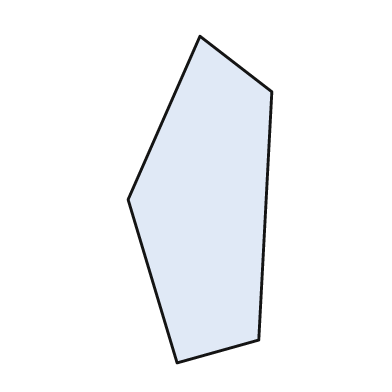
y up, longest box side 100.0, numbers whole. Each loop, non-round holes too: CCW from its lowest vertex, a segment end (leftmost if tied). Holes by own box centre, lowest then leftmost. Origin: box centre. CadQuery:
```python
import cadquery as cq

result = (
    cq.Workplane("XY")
    .moveTo(-7.0, -50.0)
    .lineTo(18.0, -43.0)
    .lineTo(22.0, 33.0)
    .lineTo(0.0, 50.0)
    .lineTo(-22.0, 0.0)
    .close()
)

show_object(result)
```